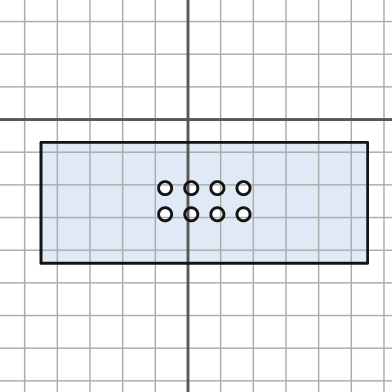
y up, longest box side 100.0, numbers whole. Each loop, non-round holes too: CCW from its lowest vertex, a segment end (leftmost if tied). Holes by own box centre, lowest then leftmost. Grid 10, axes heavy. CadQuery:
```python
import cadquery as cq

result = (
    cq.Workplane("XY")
    .moveTo(-45.0, -44.0)
    .lineTo(55.0, -44.0)
    .lineTo(55.0, -7.0)
    .lineTo(-45.0, -7.0)
    .close()
    .moveTo(-7.0, -29.0)
    .circle(2.0)
    .moveTo(1.0, -29.0)
    .circle(2.0)
    .moveTo(9.0, -29.0)
    .circle(2.0)
    .moveTo(17.0, -29.0)
    .circle(2.0)
    .moveTo(-7.0, -21.0)
    .circle(2.0)
    .moveTo(1.0, -21.0)
    .circle(2.0)
    .moveTo(9.0, -21.0)
    .circle(2.0)
    .moveTo(17.0, -21.0)
    .circle(2.0)
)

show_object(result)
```